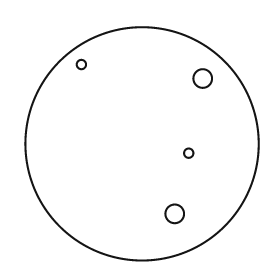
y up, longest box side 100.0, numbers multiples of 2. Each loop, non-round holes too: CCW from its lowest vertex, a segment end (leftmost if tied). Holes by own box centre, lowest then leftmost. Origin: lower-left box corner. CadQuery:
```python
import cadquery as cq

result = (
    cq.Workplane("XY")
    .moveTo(50.0, 50.0)
    .circle(50.0)
    .moveTo(64.0, 20.0)
    .circle(4.0)
    .moveTo(70.0, 46.0)
    .circle(2.0)
    .moveTo(76.0, 78.0)
    .circle(4.0)
    .moveTo(24.0, 84.0)
    .circle(2.0)
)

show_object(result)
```